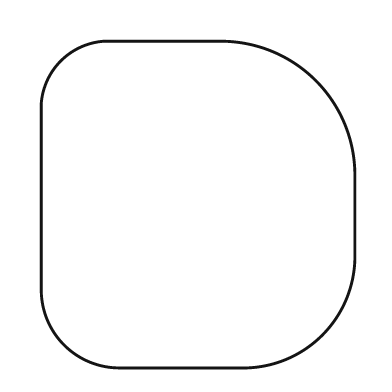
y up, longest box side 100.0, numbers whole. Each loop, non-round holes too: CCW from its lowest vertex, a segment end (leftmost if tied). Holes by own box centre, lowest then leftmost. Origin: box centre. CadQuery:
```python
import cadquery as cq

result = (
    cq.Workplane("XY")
    .moveTo(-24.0, -50.0)
    .lineTo(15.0, -50.0)
    .threePointArc((38.0, -40.0), (48.0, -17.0))
    .lineTo(48.0, 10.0)
    .threePointArc((36.0, 38.0), (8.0, 50.0))
    .lineTo(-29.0, 50.0)
    .threePointArc((-42.0, 44.0), (-48.0, 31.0))
    .lineTo(-48.0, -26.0)
    .threePointArc((-41.0, -43.0), (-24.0, -50.0))
    .close()
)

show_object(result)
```